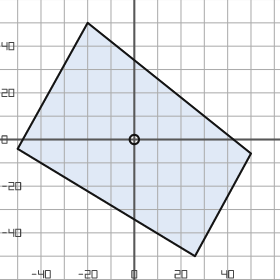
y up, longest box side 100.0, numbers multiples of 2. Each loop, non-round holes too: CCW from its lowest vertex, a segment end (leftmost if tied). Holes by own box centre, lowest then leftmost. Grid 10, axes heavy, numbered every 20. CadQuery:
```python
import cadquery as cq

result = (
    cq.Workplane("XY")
    .moveTo(26.0, -50.0)
    .lineTo(50.0, -6.0)
    .lineTo(-20.0, 50.0)
    .lineTo(-50.0, -4.0)
    .close()
    .moveTo(0.0, 0.0)
    .circle(2.0)
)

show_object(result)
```